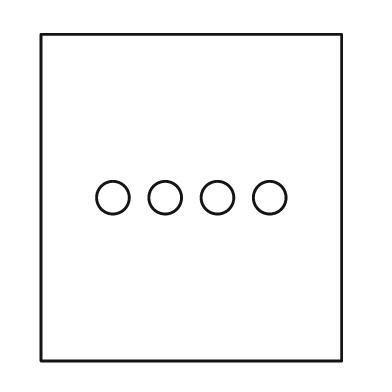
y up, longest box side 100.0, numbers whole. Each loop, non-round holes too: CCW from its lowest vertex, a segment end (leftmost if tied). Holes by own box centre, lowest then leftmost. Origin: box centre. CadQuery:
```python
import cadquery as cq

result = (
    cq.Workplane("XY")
    .moveTo(-46.0, -50.0)
    .lineTo(46.0, -50.0)
    .lineTo(46.0, 50.0)
    .lineTo(-46.0, 50.0)
    .close()
    .moveTo(-24.0, 0.0)
    .circle(5.0)
    .moveTo(-8.0, 0.0)
    .circle(5.0)
    .moveTo(8.0, 0.0)
    .circle(5.0)
    .moveTo(24.0, 0.0)
    .circle(5.0)
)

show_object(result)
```